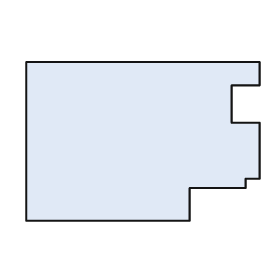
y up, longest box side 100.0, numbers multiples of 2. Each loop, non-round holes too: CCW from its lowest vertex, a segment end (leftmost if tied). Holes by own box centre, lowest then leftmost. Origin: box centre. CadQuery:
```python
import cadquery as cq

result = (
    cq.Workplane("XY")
    .moveTo(-50.0, -34.0)
    .lineTo(20.0, -34.0)
    .lineTo(20.0, -20.0)
    .lineTo(44.0, -20.0)
    .lineTo(44.0, -16.0)
    .lineTo(50.0, -16.0)
    .lineTo(50.0, 8.0)
    .lineTo(38.0, 8.0)
    .lineTo(38.0, 24.0)
    .lineTo(50.0, 24.0)
    .lineTo(50.0, 34.0)
    .lineTo(-50.0, 34.0)
    .close()
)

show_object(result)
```